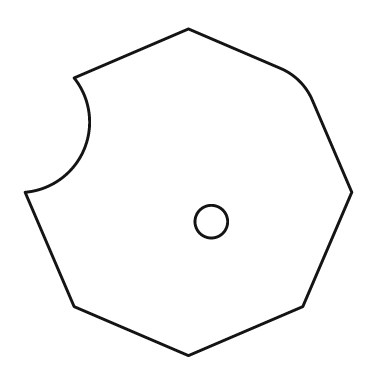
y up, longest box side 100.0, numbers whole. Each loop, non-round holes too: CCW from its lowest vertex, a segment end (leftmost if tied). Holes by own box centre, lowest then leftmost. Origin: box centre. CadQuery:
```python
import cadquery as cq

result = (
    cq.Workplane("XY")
    .moveTo(0.0, -50.0)
    .lineTo(35.0, -35.0)
    .lineTo(50.0, 0.0)
    .lineTo(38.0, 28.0)
    .threePointArc((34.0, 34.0), (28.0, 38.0))
    .lineTo(0.0, 50.0)
    .lineTo(-35.0, 35.0)
    .threePointArc((-32.0, 13.0), (-50.0, 0.0))
    .lineTo(-35.0, -35.0)
    .close()
    .moveTo(7.0, -9.0)
    .circle(5.0)
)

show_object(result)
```